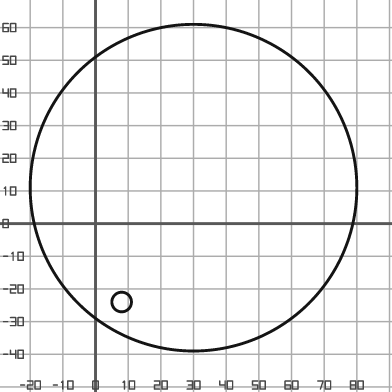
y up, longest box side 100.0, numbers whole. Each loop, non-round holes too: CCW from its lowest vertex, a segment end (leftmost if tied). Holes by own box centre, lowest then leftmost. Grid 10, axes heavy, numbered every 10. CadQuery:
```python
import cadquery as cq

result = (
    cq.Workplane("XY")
    .moveTo(30.0, 11.0)
    .circle(50.0)
    .moveTo(8.0, -24.0)
    .circle(3.0)
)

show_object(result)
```